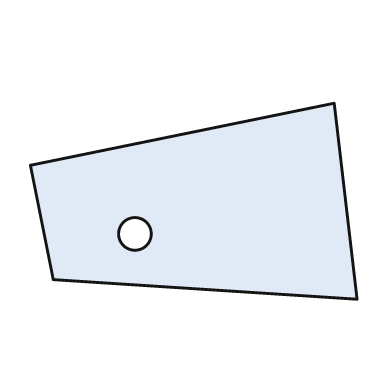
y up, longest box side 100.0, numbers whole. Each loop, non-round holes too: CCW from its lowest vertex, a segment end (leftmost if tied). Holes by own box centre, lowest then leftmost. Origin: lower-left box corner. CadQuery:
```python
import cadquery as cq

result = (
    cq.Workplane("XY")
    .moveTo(100.0, 0.0)
    .lineTo(93.0, 60.0)
    .lineTo(0.0, 41.0)
    .lineTo(7.0, 6.0)
    .close()
    .moveTo(32.0, 20.0)
    .circle(5.0)
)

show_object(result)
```